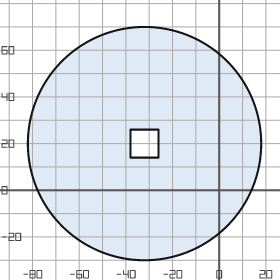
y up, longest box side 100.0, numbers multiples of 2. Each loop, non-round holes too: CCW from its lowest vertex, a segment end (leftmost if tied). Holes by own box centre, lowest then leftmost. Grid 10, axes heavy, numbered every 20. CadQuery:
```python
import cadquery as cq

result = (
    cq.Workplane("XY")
    .moveTo(-32.0, 20.0)
    .circle(50.0)
    .moveTo(-38.0, 14.0)
    .lineTo(-26.0, 14.0)
    .lineTo(-26.0, 26.0)
    .lineTo(-38.0, 26.0)
    .close()
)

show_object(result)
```